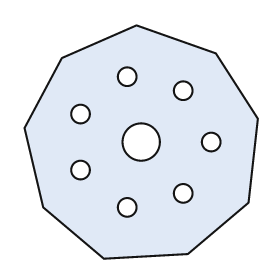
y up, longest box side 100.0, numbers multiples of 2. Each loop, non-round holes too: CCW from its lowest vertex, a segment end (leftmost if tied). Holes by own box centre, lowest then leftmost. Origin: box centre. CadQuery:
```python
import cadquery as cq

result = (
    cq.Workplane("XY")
    .moveTo(-16.0, -50.0)
    .lineTo(20.0, -48.0)
    .lineTo(46.0, -26.0)
    .lineTo(50.0, 10.0)
    .lineTo(32.0, 38.0)
    .lineTo(-2.0, 50.0)
    .lineTo(-34.0, 36.0)
    .lineTo(-50.0, 6.0)
    .lineTo(-42.0, -28.0)
    .close()
    .moveTo(-6.0, -28.0)
    .circle(4.0)
    .moveTo(18.0, -22.0)
    .circle(4.0)
    .moveTo(-26.0, -12.0)
    .circle(4.0)
    .moveTo(0.0, 0.0)
    .circle(8.0)
    .moveTo(30.0, 0.0)
    .circle(4.0)
    .moveTo(-26.0, 12.0)
    .circle(4.0)
    .moveTo(18.0, 22.0)
    .circle(4.0)
    .moveTo(-6.0, 28.0)
    .circle(4.0)
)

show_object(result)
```